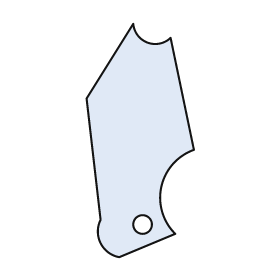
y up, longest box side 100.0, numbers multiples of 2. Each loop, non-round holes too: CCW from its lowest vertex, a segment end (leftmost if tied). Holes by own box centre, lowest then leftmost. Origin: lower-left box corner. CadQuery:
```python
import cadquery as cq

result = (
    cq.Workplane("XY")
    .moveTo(14.0, 0.0)
    .lineTo(38.0, 10.0)
    .threePointArc((32.0, 30.0), (46.0, 46.0))
    .lineTo(36.0, 94.0)
    .threePointArc((26.0, 92.0), (20.0, 100.0))
    .lineTo(0.0, 68.0)
    .lineTo(6.0, 16.0)
    .threePointArc((6.0, 6.0), (14.0, 0.0))
    .close()
    .moveTo(24.0, 14.0)
    .circle(4.0)
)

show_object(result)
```